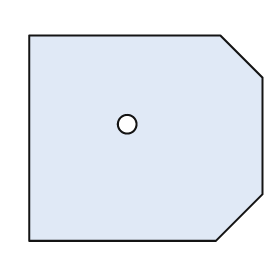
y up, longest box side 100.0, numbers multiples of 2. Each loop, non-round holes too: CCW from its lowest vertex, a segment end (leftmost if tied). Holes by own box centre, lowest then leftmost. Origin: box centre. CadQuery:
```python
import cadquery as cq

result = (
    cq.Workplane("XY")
    .moveTo(-50.0, -44.0)
    .lineTo(30.0, -44.0)
    .lineTo(50.0, -24.0)
    .lineTo(50.0, 26.0)
    .lineTo(32.0, 44.0)
    .lineTo(-50.0, 44.0)
    .close()
    .moveTo(-8.0, 6.0)
    .circle(4.0)
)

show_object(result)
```